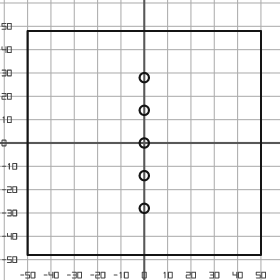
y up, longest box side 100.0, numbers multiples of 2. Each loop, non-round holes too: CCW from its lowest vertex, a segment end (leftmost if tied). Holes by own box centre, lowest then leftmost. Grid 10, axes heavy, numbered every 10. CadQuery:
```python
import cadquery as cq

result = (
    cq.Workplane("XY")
    .moveTo(-50.0, -48.0)
    .lineTo(50.0, -48.0)
    .lineTo(50.0, 48.0)
    .lineTo(-50.0, 48.0)
    .close()
    .moveTo(0.0, -28.0)
    .circle(2.0)
    .moveTo(0.0, -14.0)
    .circle(2.0)
    .moveTo(0.0, 0.0)
    .circle(2.0)
    .moveTo(0.0, 14.0)
    .circle(2.0)
    .moveTo(0.0, 28.0)
    .circle(2.0)
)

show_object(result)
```